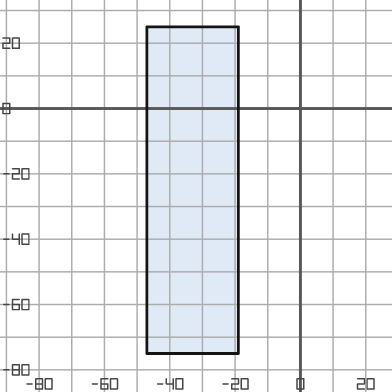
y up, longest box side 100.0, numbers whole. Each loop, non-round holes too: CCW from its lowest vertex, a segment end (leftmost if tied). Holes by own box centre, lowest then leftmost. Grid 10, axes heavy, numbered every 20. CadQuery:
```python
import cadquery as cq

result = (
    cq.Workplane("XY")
    .moveTo(-47.0, -75.0)
    .lineTo(-19.0, -75.0)
    .lineTo(-19.0, 25.0)
    .lineTo(-47.0, 25.0)
    .close()
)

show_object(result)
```